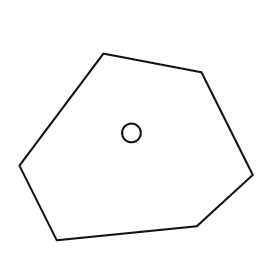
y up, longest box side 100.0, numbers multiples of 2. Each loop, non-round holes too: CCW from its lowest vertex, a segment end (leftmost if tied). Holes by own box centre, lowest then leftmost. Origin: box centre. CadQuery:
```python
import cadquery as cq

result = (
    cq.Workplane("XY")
    .moveTo(-34.0, -40.0)
    .lineTo(26.0, -34.0)
    .lineTo(50.0, -12.0)
    .lineTo(28.0, 32.0)
    .lineTo(-14.0, 40.0)
    .lineTo(-50.0, -8.0)
    .close()
    .moveTo(-2.0, 6.0)
    .circle(4.0)
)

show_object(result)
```